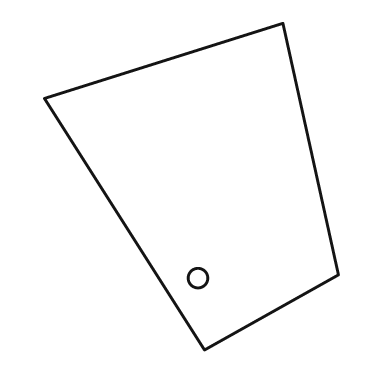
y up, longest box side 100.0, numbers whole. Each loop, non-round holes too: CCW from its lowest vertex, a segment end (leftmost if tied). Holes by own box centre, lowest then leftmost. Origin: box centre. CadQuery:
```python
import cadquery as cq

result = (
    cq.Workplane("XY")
    .moveTo(4.0, -50.0)
    .lineTo(45.0, -27.0)
    .lineTo(28.0, 50.0)
    .lineTo(-45.0, 27.0)
    .close()
    .moveTo(2.0, -28.0)
    .circle(3.0)
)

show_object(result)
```